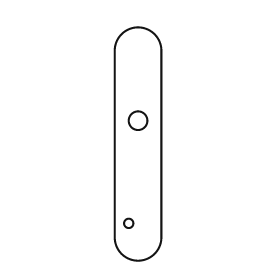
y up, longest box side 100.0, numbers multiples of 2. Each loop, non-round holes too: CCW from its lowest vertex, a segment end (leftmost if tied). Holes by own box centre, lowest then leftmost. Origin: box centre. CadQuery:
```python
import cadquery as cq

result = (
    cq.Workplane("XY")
    .moveTo(-10.0, -40.0)
    .threePointArc((0.0, -50.0), (10.0, -40.0))
    .lineTo(10.0, 40.0)
    .threePointArc((0.0, 50.0), (-10.0, 40.0))
    .close()
    .moveTo(-4.0, -34.0)
    .circle(2.0)
    .moveTo(0.0, 10.0)
    .circle(4.0)
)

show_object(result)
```